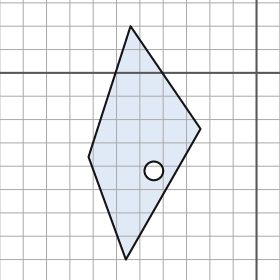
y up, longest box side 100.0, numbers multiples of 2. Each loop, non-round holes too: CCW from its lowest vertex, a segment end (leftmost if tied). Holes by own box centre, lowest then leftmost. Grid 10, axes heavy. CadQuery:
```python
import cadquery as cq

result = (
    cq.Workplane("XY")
    .moveTo(-56.0, -80.0)
    .lineTo(-24.0, -24.0)
    .lineTo(-54.0, 20.0)
    .lineTo(-72.0, -36.0)
    .close()
    .moveTo(-44.0, -42.0)
    .circle(4.0)
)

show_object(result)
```